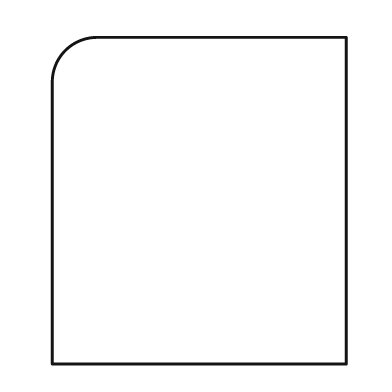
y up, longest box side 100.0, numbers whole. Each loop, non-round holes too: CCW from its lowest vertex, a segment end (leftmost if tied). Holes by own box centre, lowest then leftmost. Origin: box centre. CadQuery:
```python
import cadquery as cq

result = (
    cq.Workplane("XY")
    .moveTo(-45.0, -50.0)
    .lineTo(45.0, -50.0)
    .lineTo(45.0, 50.0)
    .lineTo(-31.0, 50.0)
    .threePointArc((-41.0, 46.0), (-45.0, 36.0))
    .close()
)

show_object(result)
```